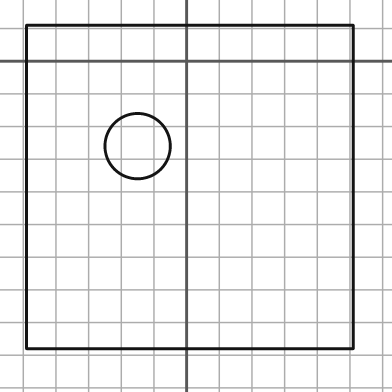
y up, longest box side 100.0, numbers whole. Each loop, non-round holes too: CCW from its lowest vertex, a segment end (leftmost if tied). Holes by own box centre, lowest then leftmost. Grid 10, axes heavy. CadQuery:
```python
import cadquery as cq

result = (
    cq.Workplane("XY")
    .moveTo(-49.0, -88.0)
    .lineTo(51.0, -88.0)
    .lineTo(51.0, 11.0)
    .lineTo(-49.0, 11.0)
    .close()
    .moveTo(-15.0, -26.0)
    .circle(10.0)
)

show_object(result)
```